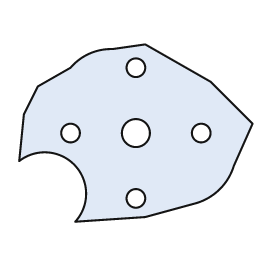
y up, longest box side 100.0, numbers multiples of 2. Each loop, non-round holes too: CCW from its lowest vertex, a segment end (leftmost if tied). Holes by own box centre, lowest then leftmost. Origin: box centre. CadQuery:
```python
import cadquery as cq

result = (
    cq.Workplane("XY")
    .moveTo(-26.0, -38.0)
    .lineTo(4.0, -36.0)
    .lineTo(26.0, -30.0)
    .threePointArc((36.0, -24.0), (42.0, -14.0))
    .lineTo(50.0, 4.0)
    .lineTo(32.0, 22.0)
    .lineTo(4.0, 38.0)
    .lineTo(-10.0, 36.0)
    .threePointArc((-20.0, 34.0), (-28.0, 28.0))
    .lineTo(-42.0, 20.0)
    .lineTo(-48.0, 8.0)
    .lineTo(-50.0, -12.0)
    .threePointArc((-26.0, -14.0), (-26.0, -38.0))
    .close()
    .moveTo(0.0, -28.0)
    .circle(4.0)
    .moveTo(-28.0, 0.0)
    .circle(4.0)
    .moveTo(0.0, 0.0)
    .circle(6.0)
    .moveTo(28.0, 0.0)
    .circle(4.0)
    .moveTo(0.0, 28.0)
    .circle(4.0)
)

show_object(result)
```